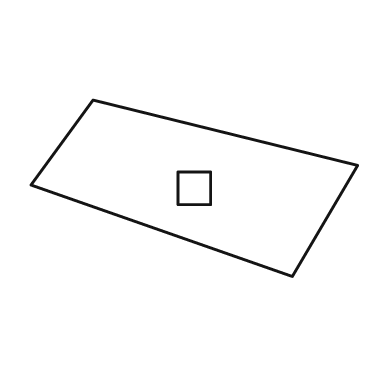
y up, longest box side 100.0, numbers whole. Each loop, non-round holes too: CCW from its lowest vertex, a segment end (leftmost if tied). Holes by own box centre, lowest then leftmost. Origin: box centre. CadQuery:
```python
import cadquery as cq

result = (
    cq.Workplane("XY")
    .moveTo(30.0, -27.0)
    .lineTo(50.0, 7.0)
    .lineTo(-31.0, 27.0)
    .lineTo(-50.0, 1.0)
    .close()
    .moveTo(-5.0, -5.0)
    .lineTo(5.0, -5.0)
    .lineTo(5.0, 5.0)
    .lineTo(-5.0, 5.0)
    .close()
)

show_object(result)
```